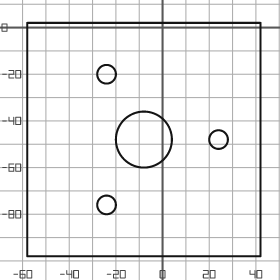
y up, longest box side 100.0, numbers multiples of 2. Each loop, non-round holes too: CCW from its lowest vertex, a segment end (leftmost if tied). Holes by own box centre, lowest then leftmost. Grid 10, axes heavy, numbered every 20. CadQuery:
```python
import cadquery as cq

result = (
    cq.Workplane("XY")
    .moveTo(-58.0, -98.0)
    .lineTo(42.0, -98.0)
    .lineTo(42.0, 2.0)
    .lineTo(-58.0, 2.0)
    .close()
    .moveTo(-24.0, -76.0)
    .circle(4.0)
    .moveTo(-8.0, -48.0)
    .circle(12.0)
    .moveTo(24.0, -48.0)
    .circle(4.0)
    .moveTo(-24.0, -20.0)
    .circle(4.0)
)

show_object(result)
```